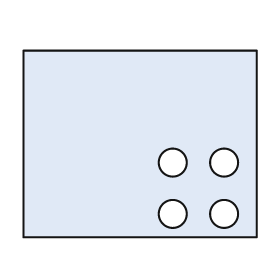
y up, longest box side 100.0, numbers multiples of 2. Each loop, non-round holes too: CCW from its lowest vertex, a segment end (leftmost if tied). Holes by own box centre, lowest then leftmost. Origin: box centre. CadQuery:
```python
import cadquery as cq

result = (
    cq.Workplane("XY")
    .moveTo(-50.0, -40.0)
    .lineTo(50.0, -40.0)
    .lineTo(50.0, 40.0)
    .lineTo(-50.0, 40.0)
    .close()
    .moveTo(14.0, -30.0)
    .circle(6.0)
    .moveTo(36.0, -30.0)
    .circle(6.0)
    .moveTo(14.0, -8.0)
    .circle(6.0)
    .moveTo(36.0, -8.0)
    .circle(6.0)
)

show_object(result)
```